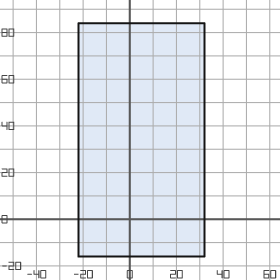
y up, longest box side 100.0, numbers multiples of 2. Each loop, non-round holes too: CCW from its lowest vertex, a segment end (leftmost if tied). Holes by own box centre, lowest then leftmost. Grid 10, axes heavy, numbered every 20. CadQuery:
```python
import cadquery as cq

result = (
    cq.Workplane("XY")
    .moveTo(-22.0, -16.0)
    .lineTo(32.0, -16.0)
    .lineTo(32.0, 84.0)
    .lineTo(-22.0, 84.0)
    .close()
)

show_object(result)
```